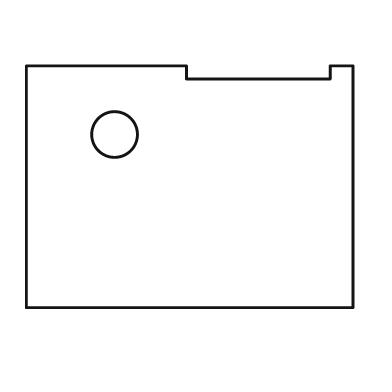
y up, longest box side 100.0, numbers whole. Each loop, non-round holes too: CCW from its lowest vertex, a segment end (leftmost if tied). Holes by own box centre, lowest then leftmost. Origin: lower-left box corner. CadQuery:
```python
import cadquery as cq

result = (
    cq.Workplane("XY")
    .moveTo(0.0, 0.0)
    .lineTo(100.0, 0.0)
    .lineTo(100.0, 74.0)
    .lineTo(93.0, 74.0)
    .lineTo(93.0, 70.0)
    .lineTo(49.0, 70.0)
    .lineTo(49.0, 74.0)
    .lineTo(0.0, 74.0)
    .close()
    .moveTo(27.0, 53.0)
    .circle(7.0)
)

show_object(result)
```